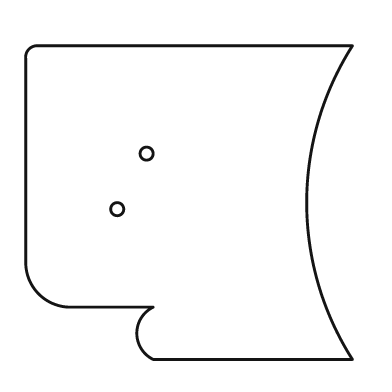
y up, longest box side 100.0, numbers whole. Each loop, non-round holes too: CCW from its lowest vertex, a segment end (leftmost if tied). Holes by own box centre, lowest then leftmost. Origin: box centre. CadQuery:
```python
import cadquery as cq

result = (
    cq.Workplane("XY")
    .moveTo(-11.0, -48.0)
    .lineTo(50.0, -48.0)
    .threePointArc((36.0, 0.0), (50.0, 48.0))
    .lineTo(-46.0, 48.0)
    .threePointArc((-49.0, 47.0), (-50.0, 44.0))
    .lineTo(-50.0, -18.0)
    .threePointArc((-46.0, -28.0), (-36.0, -32.0))
    .lineTo(-11.0, -32.0)
    .threePointArc((-16.0, -40.0), (-11.0, -48.0))
    .close()
    .moveTo(-22.0, -2.0)
    .circle(2.0)
    .moveTo(-13.0, 15.0)
    .circle(2.0)
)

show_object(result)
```